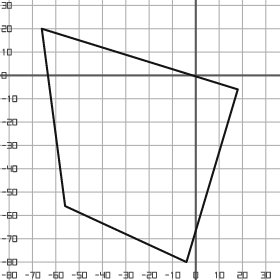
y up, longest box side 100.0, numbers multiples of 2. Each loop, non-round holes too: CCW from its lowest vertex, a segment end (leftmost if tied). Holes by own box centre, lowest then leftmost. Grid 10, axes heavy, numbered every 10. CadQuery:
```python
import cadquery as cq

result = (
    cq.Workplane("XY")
    .moveTo(-4.0, -80.0)
    .lineTo(18.0, -6.0)
    .lineTo(-66.0, 20.0)
    .lineTo(-56.0, -56.0)
    .close()
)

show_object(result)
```